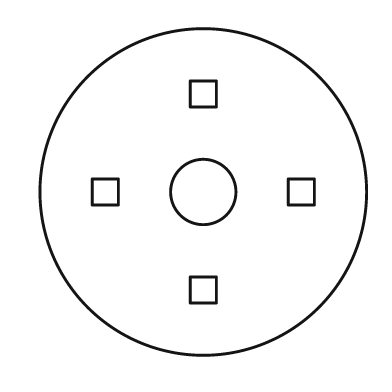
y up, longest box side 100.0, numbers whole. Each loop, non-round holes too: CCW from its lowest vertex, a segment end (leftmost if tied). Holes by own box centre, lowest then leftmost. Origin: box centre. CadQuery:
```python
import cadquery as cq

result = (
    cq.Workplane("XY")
    .moveTo(0.0, 0.0)
    .circle(50.0)
    .moveTo(-4.0, -34.0)
    .lineTo(4.0, -34.0)
    .lineTo(4.0, -26.0)
    .lineTo(-4.0, -26.0)
    .close()
    .moveTo(-34.0, -4.0)
    .lineTo(-26.0, -4.0)
    .lineTo(-26.0, 4.0)
    .lineTo(-34.0, 4.0)
    .close()
    .moveTo(0.0, 0.0)
    .circle(10.0)
    .moveTo(26.0, -4.0)
    .lineTo(34.0, -4.0)
    .lineTo(34.0, 4.0)
    .lineTo(26.0, 4.0)
    .close()
    .moveTo(-4.0, 26.0)
    .lineTo(4.0, 26.0)
    .lineTo(4.0, 34.0)
    .lineTo(-4.0, 34.0)
    .close()
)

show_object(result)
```